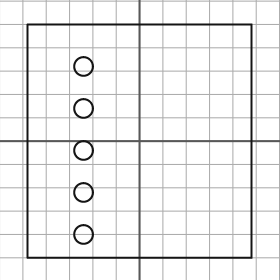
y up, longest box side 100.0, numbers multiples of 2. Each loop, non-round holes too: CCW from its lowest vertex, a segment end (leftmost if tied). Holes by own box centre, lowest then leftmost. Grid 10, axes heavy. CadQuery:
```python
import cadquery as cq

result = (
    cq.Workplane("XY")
    .moveTo(-48.0, -50.0)
    .lineTo(48.0, -50.0)
    .lineTo(48.0, 50.0)
    .lineTo(-48.0, 50.0)
    .close()
    .moveTo(-24.0, -40.0)
    .circle(4.0)
    .moveTo(-24.0, -22.0)
    .circle(4.0)
    .moveTo(-24.0, -4.0)
    .circle(4.0)
    .moveTo(-24.0, 14.0)
    .circle(4.0)
    .moveTo(-24.0, 32.0)
    .circle(4.0)
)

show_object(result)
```